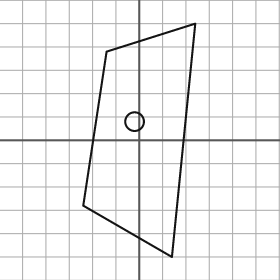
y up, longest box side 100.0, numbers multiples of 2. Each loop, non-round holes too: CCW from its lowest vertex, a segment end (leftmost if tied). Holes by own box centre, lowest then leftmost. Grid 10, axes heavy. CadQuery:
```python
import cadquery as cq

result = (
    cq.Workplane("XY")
    .moveTo(14.0, -50.0)
    .lineTo(24.0, 50.0)
    .lineTo(-14.0, 38.0)
    .lineTo(-24.0, -28.0)
    .close()
    .moveTo(-2.0, 8.0)
    .circle(4.0)
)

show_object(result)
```